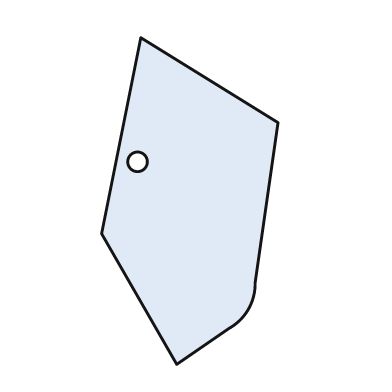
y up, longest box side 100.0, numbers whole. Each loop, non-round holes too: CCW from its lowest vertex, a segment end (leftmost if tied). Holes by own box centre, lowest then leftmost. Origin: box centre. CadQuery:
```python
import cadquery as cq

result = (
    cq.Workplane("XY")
    .moveTo(-4.0, -50.0)
    .lineTo(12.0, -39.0)
    .threePointArc((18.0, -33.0), (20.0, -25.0))
    .lineTo(27.0, 24.0)
    .lineTo(-15.0, 50.0)
    .lineTo(-27.0, -10.0)
    .close()
    .moveTo(-16.0, 12.0)
    .circle(3.0)
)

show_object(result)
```